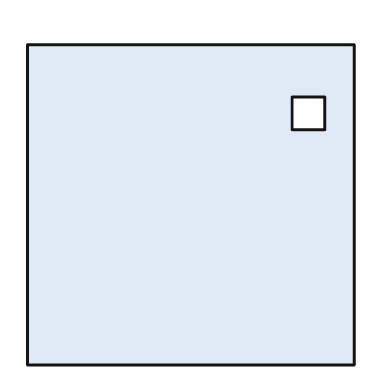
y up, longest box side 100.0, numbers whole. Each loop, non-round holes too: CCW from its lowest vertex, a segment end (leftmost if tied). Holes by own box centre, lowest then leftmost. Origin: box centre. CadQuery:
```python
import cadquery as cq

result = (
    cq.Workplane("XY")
    .moveTo(-50.0, -49.0)
    .lineTo(50.0, -49.0)
    .lineTo(50.0, 49.0)
    .lineTo(-50.0, 49.0)
    .close()
    .moveTo(31.0, 23.0)
    .lineTo(41.0, 23.0)
    .lineTo(41.0, 33.0)
    .lineTo(31.0, 33.0)
    .close()
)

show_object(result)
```